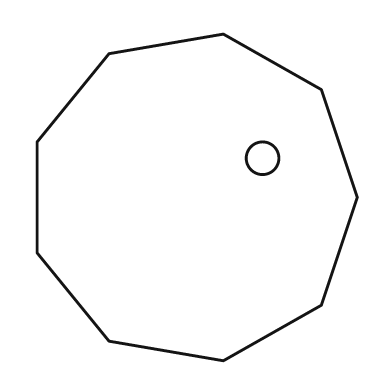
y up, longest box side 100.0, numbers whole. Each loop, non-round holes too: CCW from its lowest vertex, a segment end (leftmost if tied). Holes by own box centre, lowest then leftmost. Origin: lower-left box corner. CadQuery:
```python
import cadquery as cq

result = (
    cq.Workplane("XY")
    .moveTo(57.0, 0.0)
    .lineTo(87.0, 17.0)
    .lineTo(98.0, 50.0)
    .lineTo(87.0, 83.0)
    .lineTo(57.0, 100.0)
    .lineTo(22.0, 94.0)
    .lineTo(0.0, 67.0)
    .lineTo(0.0, 33.0)
    .lineTo(22.0, 6.0)
    .close()
    .moveTo(69.0, 62.0)
    .circle(5.0)
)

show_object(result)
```